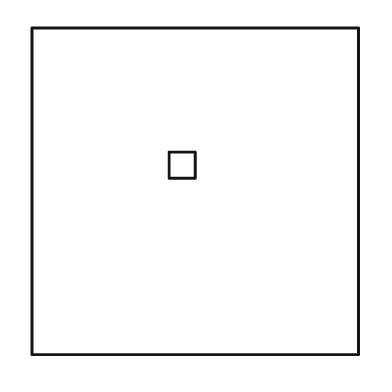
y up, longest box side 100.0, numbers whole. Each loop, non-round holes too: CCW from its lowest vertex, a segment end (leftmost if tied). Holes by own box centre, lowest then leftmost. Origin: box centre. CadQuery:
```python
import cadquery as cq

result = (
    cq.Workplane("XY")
    .moveTo(-50.0, -50.0)
    .lineTo(50.0, -50.0)
    .lineTo(50.0, 50.0)
    .lineTo(-50.0, 50.0)
    .close()
    .moveTo(-8.0, 4.0)
    .lineTo(0.0, 4.0)
    .lineTo(0.0, 12.0)
    .lineTo(-8.0, 12.0)
    .close()
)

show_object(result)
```